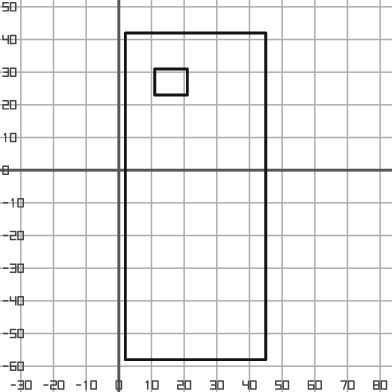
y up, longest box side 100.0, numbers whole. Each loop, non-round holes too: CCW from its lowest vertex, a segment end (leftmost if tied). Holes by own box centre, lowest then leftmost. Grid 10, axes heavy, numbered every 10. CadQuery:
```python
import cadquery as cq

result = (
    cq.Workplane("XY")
    .moveTo(2.0, -58.0)
    .lineTo(45.0, -58.0)
    .lineTo(45.0, 42.0)
    .lineTo(2.0, 42.0)
    .close()
    .moveTo(11.0, 23.0)
    .lineTo(21.0, 23.0)
    .lineTo(21.0, 31.0)
    .lineTo(11.0, 31.0)
    .close()
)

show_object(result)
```